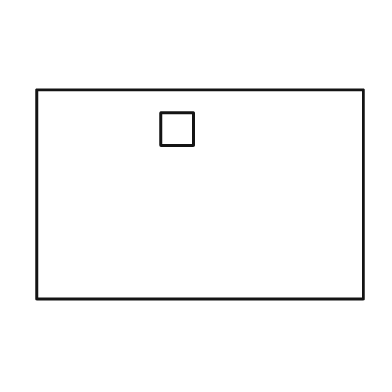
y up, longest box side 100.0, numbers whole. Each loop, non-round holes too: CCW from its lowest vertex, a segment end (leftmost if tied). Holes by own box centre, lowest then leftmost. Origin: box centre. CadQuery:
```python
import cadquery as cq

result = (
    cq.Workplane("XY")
    .moveTo(-50.0, -32.0)
    .lineTo(50.0, -32.0)
    .lineTo(50.0, 32.0)
    .lineTo(-50.0, 32.0)
    .close()
    .moveTo(-12.0, 15.0)
    .lineTo(-2.0, 15.0)
    .lineTo(-2.0, 25.0)
    .lineTo(-12.0, 25.0)
    .close()
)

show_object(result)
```